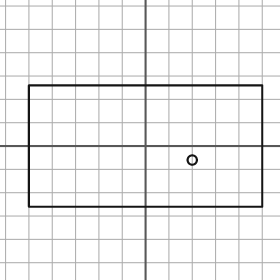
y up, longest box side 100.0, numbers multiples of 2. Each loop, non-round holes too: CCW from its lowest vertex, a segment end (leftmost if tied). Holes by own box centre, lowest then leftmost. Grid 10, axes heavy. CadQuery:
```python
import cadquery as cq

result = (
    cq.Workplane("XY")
    .moveTo(-50.0, -26.0)
    .lineTo(50.0, -26.0)
    .lineTo(50.0, 26.0)
    .lineTo(-50.0, 26.0)
    .close()
    .moveTo(20.0, -6.0)
    .circle(2.0)
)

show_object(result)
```